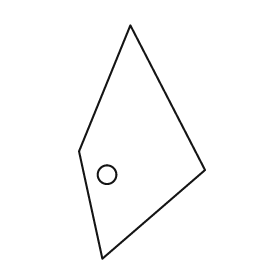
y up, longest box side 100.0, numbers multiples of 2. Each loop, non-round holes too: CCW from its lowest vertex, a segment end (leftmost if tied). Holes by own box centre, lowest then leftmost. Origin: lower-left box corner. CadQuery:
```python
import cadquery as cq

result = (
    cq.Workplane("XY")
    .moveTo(10.0, 0.0)
    .lineTo(54.0, 38.0)
    .lineTo(22.0, 100.0)
    .lineTo(0.0, 46.0)
    .close()
    .moveTo(12.0, 36.0)
    .circle(4.0)
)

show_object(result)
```